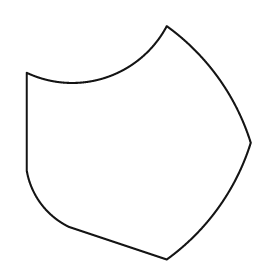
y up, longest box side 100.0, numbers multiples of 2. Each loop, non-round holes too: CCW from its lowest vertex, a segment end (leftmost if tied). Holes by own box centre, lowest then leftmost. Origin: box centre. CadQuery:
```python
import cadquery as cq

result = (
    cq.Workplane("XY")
    .moveTo(12.0, -50.0)
    .threePointArc((34.0, -28.0), (48.0, 0.0))
    .threePointArc((34.0, 28.0), (12.0, 50.0))
    .threePointArc((-14.0, 28.0), (-48.0, 30.0))
    .lineTo(-48.0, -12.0)
    .threePointArc((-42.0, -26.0), (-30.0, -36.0))
    .close()
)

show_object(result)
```